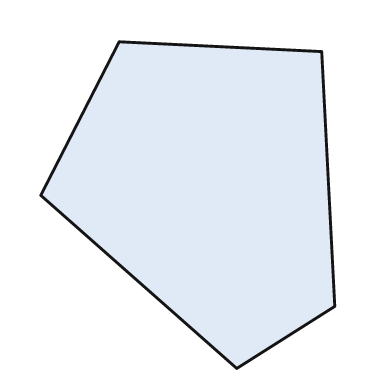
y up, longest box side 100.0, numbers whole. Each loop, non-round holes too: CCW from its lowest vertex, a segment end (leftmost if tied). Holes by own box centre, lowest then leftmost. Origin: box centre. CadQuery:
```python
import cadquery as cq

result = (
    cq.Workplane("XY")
    .moveTo(15.0, -50.0)
    .lineTo(45.0, -31.0)
    .lineTo(41.0, 47.0)
    .lineTo(-21.0, 50.0)
    .lineTo(-45.0, 3.0)
    .close()
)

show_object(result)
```